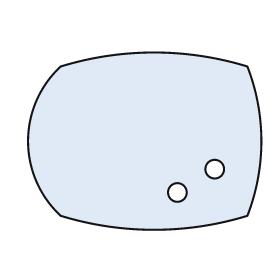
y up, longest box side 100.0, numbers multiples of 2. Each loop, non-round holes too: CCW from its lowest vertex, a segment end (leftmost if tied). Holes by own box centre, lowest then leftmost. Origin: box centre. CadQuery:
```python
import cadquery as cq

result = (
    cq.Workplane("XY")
    .moveTo(-36.0, -32.0)
    .threePointArc((4.0, -38.0), (44.0, -32.0))
    .threePointArc((50.0, 0.0), (44.0, 32.0))
    .threePointArc((4.0, 38.0), (-36.0, 32.0))
    .threePointArc((-50.0, 0.0), (-36.0, -32.0))
    .close()
    .moveTo(14.0, -22.0)
    .circle(4.0)
    .moveTo(30.0, -12.0)
    .circle(4.0)
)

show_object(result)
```